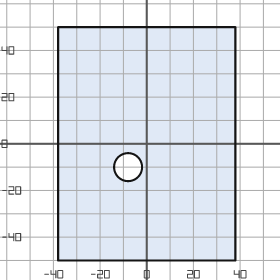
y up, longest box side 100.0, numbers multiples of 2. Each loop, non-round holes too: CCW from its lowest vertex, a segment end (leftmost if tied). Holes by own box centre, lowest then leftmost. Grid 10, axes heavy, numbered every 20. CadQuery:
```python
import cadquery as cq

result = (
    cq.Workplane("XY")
    .moveTo(-38.0, -50.0)
    .lineTo(38.0, -50.0)
    .lineTo(38.0, 50.0)
    .lineTo(-38.0, 50.0)
    .close()
    .moveTo(-8.0, -10.0)
    .circle(6.0)
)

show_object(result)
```